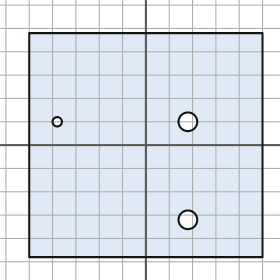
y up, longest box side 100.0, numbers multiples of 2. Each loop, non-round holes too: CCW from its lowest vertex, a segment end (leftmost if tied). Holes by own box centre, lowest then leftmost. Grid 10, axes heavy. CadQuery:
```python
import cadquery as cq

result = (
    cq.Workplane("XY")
    .moveTo(-50.0, -48.0)
    .lineTo(50.0, -48.0)
    .lineTo(50.0, 48.0)
    .lineTo(-50.0, 48.0)
    .close()
    .moveTo(18.0, -32.0)
    .circle(4.0)
    .moveTo(-38.0, 10.0)
    .circle(2.0)
    .moveTo(18.0, 10.0)
    .circle(4.0)
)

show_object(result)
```